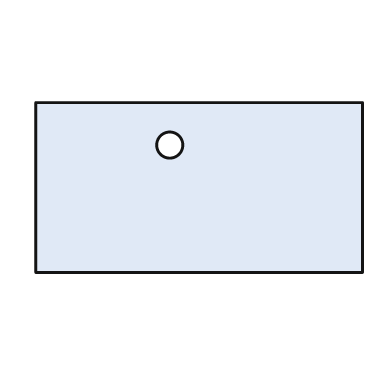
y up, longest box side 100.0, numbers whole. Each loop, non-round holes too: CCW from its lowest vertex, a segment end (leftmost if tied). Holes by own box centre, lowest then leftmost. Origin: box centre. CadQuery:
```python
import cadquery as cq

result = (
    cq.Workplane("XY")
    .moveTo(-50.0, -26.0)
    .lineTo(50.0, -26.0)
    .lineTo(50.0, 26.0)
    .lineTo(-50.0, 26.0)
    .close()
    .moveTo(-9.0, 13.0)
    .circle(4.0)
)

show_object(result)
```